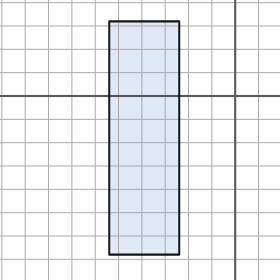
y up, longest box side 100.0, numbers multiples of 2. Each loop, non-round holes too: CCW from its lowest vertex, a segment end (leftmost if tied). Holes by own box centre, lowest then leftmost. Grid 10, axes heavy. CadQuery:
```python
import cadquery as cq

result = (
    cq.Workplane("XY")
    .moveTo(-54.0, -68.0)
    .lineTo(-24.0, -68.0)
    .lineTo(-24.0, 32.0)
    .lineTo(-54.0, 32.0)
    .close()
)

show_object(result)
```